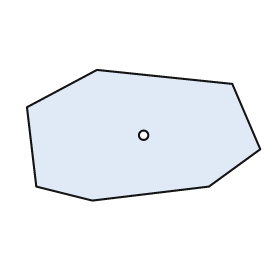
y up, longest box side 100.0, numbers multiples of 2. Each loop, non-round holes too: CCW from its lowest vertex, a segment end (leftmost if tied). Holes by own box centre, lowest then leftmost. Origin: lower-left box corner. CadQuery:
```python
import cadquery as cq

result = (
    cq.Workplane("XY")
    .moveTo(28.0, 0.0)
    .lineTo(78.0, 6.0)
    .lineTo(100.0, 22.0)
    .lineTo(88.0, 50.0)
    .lineTo(30.0, 56.0)
    .lineTo(0.0, 40.0)
    .lineTo(4.0, 6.0)
    .close()
    .moveTo(50.0, 28.0)
    .circle(2.0)
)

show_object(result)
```